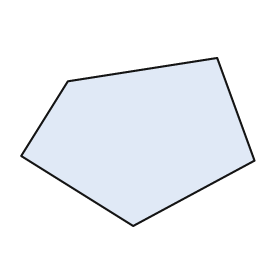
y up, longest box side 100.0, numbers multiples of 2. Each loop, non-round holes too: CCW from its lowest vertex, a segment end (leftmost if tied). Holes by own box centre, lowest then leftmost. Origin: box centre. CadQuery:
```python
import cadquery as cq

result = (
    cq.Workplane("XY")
    .moveTo(-2.0, -36.0)
    .lineTo(50.0, -8.0)
    .lineTo(34.0, 36.0)
    .lineTo(-30.0, 26.0)
    .lineTo(-50.0, -6.0)
    .close()
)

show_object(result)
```